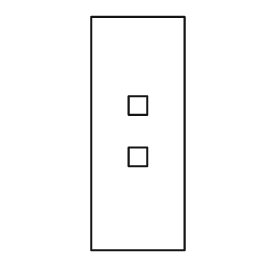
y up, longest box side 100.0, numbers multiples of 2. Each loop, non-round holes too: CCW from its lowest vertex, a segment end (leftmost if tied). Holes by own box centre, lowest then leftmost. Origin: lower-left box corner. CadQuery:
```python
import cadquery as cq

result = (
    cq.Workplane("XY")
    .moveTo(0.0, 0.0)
    .lineTo(40.0, 0.0)
    .lineTo(40.0, 100.0)
    .lineTo(0.0, 100.0)
    .close()
    .moveTo(16.0, 36.0)
    .lineTo(24.0, 36.0)
    .lineTo(24.0, 44.0)
    .lineTo(16.0, 44.0)
    .close()
    .moveTo(16.0, 58.0)
    .lineTo(24.0, 58.0)
    .lineTo(24.0, 66.0)
    .lineTo(16.0, 66.0)
    .close()
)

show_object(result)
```